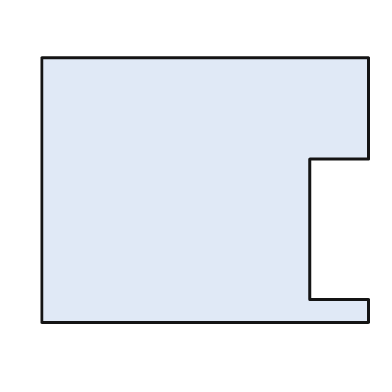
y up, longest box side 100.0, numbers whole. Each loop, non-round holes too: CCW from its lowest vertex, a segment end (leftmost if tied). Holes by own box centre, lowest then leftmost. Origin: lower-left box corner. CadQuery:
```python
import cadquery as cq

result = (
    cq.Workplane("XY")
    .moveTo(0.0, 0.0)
    .lineTo(100.0, 0.0)
    .lineTo(100.0, 7.0)
    .lineTo(82.0, 7.0)
    .lineTo(82.0, 50.0)
    .lineTo(100.0, 50.0)
    .lineTo(100.0, 81.0)
    .lineTo(0.0, 81.0)
    .close()
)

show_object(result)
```